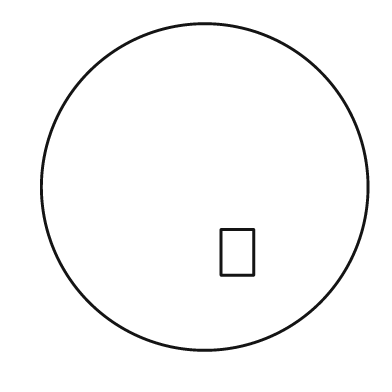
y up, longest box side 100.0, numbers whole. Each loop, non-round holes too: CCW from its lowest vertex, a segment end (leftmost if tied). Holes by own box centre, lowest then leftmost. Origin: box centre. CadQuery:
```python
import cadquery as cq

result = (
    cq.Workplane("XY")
    .moveTo(0.0, 0.0)
    .circle(50.0)
    .moveTo(5.0, -27.0)
    .lineTo(15.0, -27.0)
    .lineTo(15.0, -13.0)
    .lineTo(5.0, -13.0)
    .close()
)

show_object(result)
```